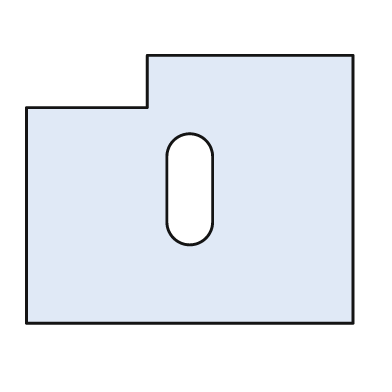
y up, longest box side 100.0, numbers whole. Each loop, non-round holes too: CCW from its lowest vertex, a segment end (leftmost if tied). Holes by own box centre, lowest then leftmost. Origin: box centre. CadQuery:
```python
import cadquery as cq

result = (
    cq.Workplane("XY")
    .moveTo(-50.0, -41.0)
    .lineTo(50.0, -41.0)
    .lineTo(50.0, 41.0)
    .lineTo(-13.0, 41.0)
    .lineTo(-13.0, 25.0)
    .lineTo(-50.0, 25.0)
    .close()
    .moveTo(-7.0, -10.0)
    .threePointArc((0.0, -17.0), (7.0, -10.0))
    .lineTo(7.0, 10.0)
    .threePointArc((0.0, 17.0), (-7.0, 10.0))
    .close()
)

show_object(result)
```